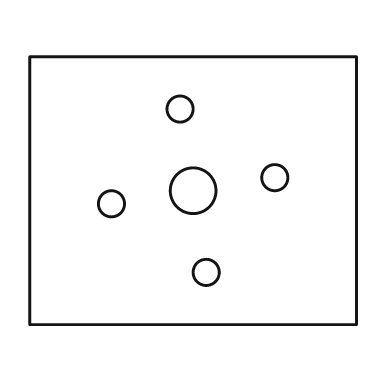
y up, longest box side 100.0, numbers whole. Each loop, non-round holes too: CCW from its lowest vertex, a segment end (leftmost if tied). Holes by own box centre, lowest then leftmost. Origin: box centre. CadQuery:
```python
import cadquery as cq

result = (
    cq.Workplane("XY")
    .moveTo(-50.0, -41.0)
    .lineTo(50.0, -41.0)
    .lineTo(50.0, 41.0)
    .lineTo(-50.0, 41.0)
    .close()
    .moveTo(4.0, -25.0)
    .circle(4.0)
    .moveTo(-25.0, -4.0)
    .circle(4.0)
    .moveTo(0.0, 0.0)
    .circle(7.0)
    .moveTo(25.0, 4.0)
    .circle(4.0)
    .moveTo(-4.0, 25.0)
    .circle(4.0)
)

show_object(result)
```